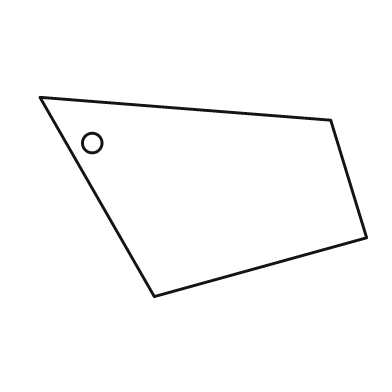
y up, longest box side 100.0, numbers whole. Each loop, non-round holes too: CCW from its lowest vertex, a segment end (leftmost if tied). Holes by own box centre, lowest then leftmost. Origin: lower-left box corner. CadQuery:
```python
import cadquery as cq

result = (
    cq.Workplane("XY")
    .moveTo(35.0, 0.0)
    .lineTo(100.0, 18.0)
    .lineTo(89.0, 54.0)
    .lineTo(0.0, 61.0)
    .close()
    .moveTo(16.0, 47.0)
    .circle(3.0)
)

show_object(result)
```